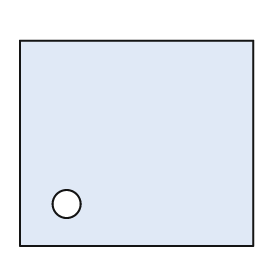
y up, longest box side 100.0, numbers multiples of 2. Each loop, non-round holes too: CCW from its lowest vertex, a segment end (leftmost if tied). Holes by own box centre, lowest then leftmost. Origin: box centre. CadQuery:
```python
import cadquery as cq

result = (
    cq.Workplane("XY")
    .moveTo(-50.0, -44.0)
    .lineTo(50.0, -44.0)
    .lineTo(50.0, 44.0)
    .lineTo(-50.0, 44.0)
    .close()
    .moveTo(-30.0, -26.0)
    .circle(6.0)
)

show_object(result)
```